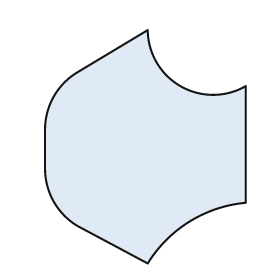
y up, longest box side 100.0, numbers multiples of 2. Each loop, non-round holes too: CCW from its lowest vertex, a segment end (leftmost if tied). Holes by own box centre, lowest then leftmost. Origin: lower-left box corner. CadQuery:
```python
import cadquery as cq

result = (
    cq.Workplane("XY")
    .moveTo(44.0, 0.0)
    .threePointArc((62.0, 18.0), (86.0, 26.0))
    .lineTo(86.0, 76.0)
    .threePointArc((58.0, 76.0), (44.0, 100.0))
    .lineTo(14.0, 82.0)
    .threePointArc((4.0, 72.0), (0.0, 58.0))
    .lineTo(0.0, 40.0)
    .threePointArc((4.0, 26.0), (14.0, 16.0))
    .close()
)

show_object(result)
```